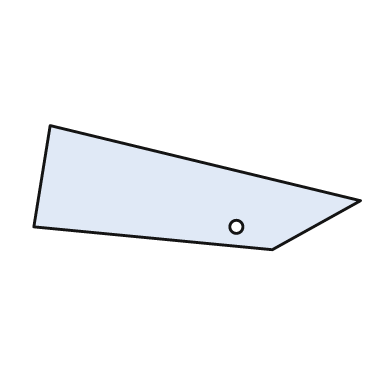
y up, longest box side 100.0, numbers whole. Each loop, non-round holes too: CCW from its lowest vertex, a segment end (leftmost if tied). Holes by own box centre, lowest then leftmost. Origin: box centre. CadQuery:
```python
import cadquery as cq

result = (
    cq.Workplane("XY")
    .moveTo(23.0, -19.0)
    .lineTo(50.0, -4.0)
    .lineTo(-45.0, 19.0)
    .lineTo(-50.0, -12.0)
    .close()
    .moveTo(12.0, -12.0)
    .circle(2.0)
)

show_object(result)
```